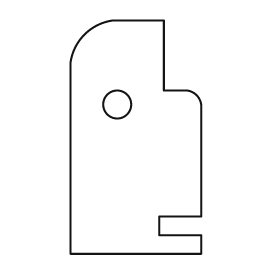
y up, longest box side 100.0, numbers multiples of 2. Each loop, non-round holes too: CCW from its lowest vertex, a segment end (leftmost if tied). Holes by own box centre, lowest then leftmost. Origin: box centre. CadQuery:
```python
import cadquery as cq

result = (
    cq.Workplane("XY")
    .moveTo(-28.0, -50.0)
    .lineTo(28.0, -50.0)
    .lineTo(28.0, -42.0)
    .lineTo(10.0, -42.0)
    .lineTo(10.0, -34.0)
    .lineTo(28.0, -34.0)
    .lineTo(28.0, 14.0)
    .threePointArc((26.0, 18.0), (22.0, 20.0))
    .lineTo(12.0, 20.0)
    .lineTo(12.0, 50.0)
    .lineTo(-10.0, 50.0)
    .threePointArc((-22.0, 44.0), (-28.0, 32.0))
    .close()
    .moveTo(-8.0, 14.0)
    .circle(6.0)
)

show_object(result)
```